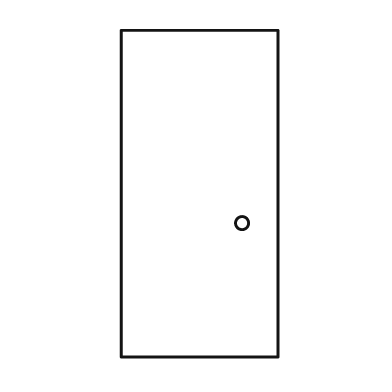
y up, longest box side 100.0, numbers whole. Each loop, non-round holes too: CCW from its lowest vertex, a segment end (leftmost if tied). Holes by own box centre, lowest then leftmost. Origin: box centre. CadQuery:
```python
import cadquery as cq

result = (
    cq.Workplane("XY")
    .moveTo(-24.0, -50.0)
    .lineTo(24.0, -50.0)
    .lineTo(24.0, 50.0)
    .lineTo(-24.0, 50.0)
    .close()
    .moveTo(13.0, -9.0)
    .circle(2.0)
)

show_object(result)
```